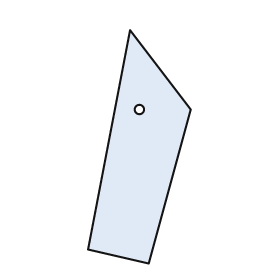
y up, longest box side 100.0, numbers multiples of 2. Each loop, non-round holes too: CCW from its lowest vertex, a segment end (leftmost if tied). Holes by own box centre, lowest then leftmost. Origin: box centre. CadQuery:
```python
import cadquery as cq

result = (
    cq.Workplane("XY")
    .moveTo(4.0, -50.0)
    .lineTo(22.0, 16.0)
    .lineTo(-4.0, 50.0)
    .lineTo(-22.0, -44.0)
    .close()
    .moveTo(0.0, 16.0)
    .circle(2.0)
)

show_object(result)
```